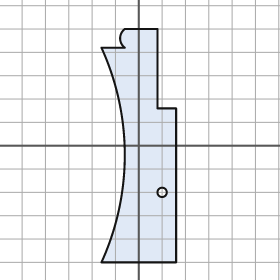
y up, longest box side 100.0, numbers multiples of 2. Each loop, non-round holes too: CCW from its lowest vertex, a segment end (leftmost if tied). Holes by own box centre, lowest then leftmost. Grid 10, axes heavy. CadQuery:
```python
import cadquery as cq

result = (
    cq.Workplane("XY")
    .moveTo(-16.0, -50.0)
    .lineTo(16.0, -50.0)
    .lineTo(16.0, 16.0)
    .lineTo(8.0, 16.0)
    .lineTo(8.0, 50.0)
    .lineTo(-6.0, 50.0)
    .threePointArc((-8.0, 46.0), (-6.0, 42.0))
    .lineTo(-16.0, 42.0)
    .threePointArc((-6.0, -4.0), (-16.0, -50.0))
    .close()
    .moveTo(10.0, -20.0)
    .circle(2.0)
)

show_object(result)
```